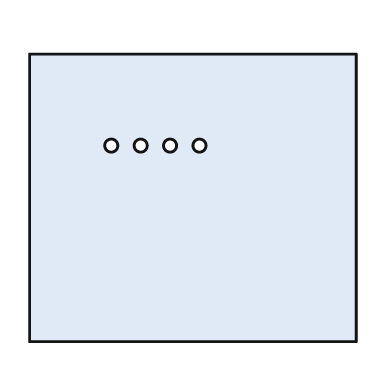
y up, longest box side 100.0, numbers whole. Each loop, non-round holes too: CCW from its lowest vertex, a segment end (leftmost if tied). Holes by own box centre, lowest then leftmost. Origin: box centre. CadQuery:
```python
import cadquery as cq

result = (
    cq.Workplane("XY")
    .moveTo(-50.0, -44.0)
    .lineTo(50.0, -44.0)
    .lineTo(50.0, 44.0)
    .lineTo(-50.0, 44.0)
    .close()
    .moveTo(-25.0, 16.0)
    .circle(2.0)
    .moveTo(-16.0, 16.0)
    .circle(2.0)
    .moveTo(-7.0, 16.0)
    .circle(2.0)
    .moveTo(2.0, 16.0)
    .circle(2.0)
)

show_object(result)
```